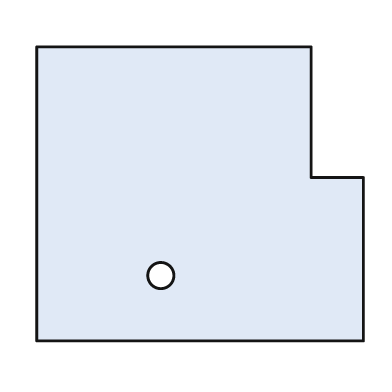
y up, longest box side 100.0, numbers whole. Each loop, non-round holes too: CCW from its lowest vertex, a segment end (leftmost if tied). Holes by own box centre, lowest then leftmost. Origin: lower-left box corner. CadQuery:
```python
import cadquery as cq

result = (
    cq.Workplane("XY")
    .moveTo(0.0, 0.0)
    .lineTo(100.0, 0.0)
    .lineTo(100.0, 50.0)
    .lineTo(84.0, 50.0)
    .lineTo(84.0, 90.0)
    .lineTo(0.0, 90.0)
    .close()
    .moveTo(38.0, 20.0)
    .circle(4.0)
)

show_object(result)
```